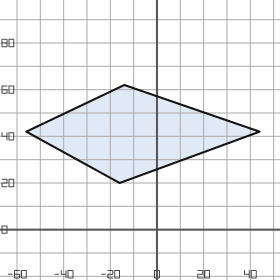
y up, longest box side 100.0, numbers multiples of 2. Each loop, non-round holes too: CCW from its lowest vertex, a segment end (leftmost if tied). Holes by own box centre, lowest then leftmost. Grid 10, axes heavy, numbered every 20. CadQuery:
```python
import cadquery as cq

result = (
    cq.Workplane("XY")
    .moveTo(-16.0, 20.0)
    .lineTo(44.0, 42.0)
    .lineTo(-14.0, 62.0)
    .lineTo(-56.0, 42.0)
    .close()
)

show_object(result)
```